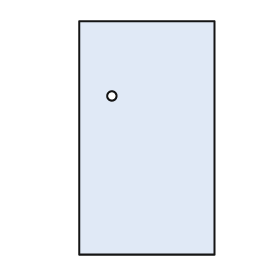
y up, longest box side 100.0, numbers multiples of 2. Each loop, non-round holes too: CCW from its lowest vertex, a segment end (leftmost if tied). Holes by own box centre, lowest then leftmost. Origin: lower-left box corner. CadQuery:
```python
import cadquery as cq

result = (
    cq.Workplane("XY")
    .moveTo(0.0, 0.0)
    .lineTo(58.0, 0.0)
    .lineTo(58.0, 100.0)
    .lineTo(0.0, 100.0)
    .close()
    .moveTo(14.0, 68.0)
    .circle(2.0)
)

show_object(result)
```